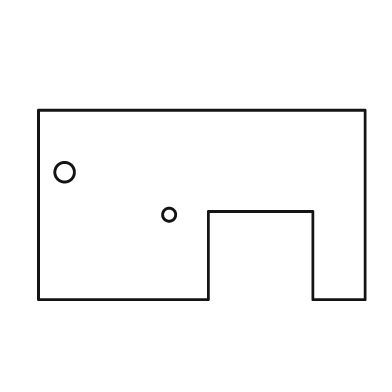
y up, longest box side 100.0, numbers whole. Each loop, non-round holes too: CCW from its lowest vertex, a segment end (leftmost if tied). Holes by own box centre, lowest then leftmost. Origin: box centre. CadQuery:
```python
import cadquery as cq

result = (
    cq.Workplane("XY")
    .moveTo(-50.0, -29.0)
    .lineTo(2.0, -29.0)
    .lineTo(2.0, -2.0)
    .lineTo(34.0, -2.0)
    .lineTo(34.0, -29.0)
    .lineTo(50.0, -29.0)
    .lineTo(50.0, 29.0)
    .lineTo(-50.0, 29.0)
    .close()
    .moveTo(-10.0, -3.0)
    .circle(2.0)
    .moveTo(-42.0, 10.0)
    .circle(3.0)
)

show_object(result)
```